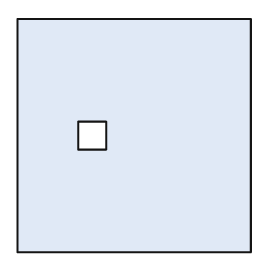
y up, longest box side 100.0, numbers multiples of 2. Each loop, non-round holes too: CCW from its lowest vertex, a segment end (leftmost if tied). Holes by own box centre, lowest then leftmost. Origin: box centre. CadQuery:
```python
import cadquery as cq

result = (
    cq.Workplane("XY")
    .moveTo(-50.0, -50.0)
    .lineTo(50.0, -50.0)
    .lineTo(50.0, 50.0)
    .lineTo(-50.0, 50.0)
    .close()
    .moveTo(-24.0, -6.0)
    .lineTo(-12.0, -6.0)
    .lineTo(-12.0, 6.0)
    .lineTo(-24.0, 6.0)
    .close()
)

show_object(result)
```